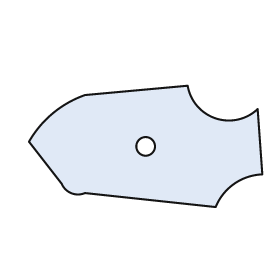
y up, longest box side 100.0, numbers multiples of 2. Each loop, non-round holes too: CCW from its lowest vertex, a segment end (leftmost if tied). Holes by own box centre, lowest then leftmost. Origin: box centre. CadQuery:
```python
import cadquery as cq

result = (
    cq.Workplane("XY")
    .moveTo(30.0, -26.0)
    .threePointArc((38.0, -16.0), (50.0, -12.0))
    .lineTo(48.0, 16.0)
    .threePointArc((30.0, 12.0), (18.0, 26.0))
    .lineTo(-26.0, 22.0)
    .threePointArc((-40.0, 14.0), (-50.0, 2.0))
    .lineTo(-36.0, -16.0)
    .threePointArc((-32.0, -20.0), (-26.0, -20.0))
    .close()
    .moveTo(0.0, 0.0)
    .circle(4.0)
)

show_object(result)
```